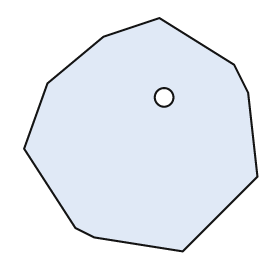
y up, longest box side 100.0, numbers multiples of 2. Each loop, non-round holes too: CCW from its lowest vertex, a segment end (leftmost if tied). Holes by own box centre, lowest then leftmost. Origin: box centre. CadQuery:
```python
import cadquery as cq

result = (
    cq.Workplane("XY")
    .moveTo(18.0, -50.0)
    .lineTo(50.0, -18.0)
    .lineTo(46.0, 18.0)
    .lineTo(40.0, 30.0)
    .lineTo(8.0, 50.0)
    .lineTo(-16.0, 42.0)
    .lineTo(-40.0, 22.0)
    .lineTo(-50.0, -6.0)
    .lineTo(-28.0, -40.0)
    .lineTo(-20.0, -44.0)
    .close()
    .moveTo(10.0, 16.0)
    .circle(4.0)
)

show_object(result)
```